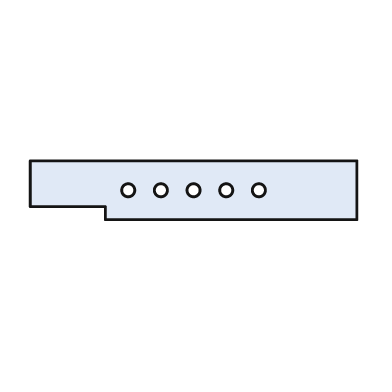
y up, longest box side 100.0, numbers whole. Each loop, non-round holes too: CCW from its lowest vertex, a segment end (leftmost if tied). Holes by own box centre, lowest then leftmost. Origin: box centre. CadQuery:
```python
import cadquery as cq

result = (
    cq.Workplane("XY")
    .moveTo(-27.0, -9.0)
    .lineTo(50.0, -9.0)
    .lineTo(50.0, 9.0)
    .lineTo(-50.0, 9.0)
    .lineTo(-50.0, -5.0)
    .lineTo(-27.0, -5.0)
    .close()
    .moveTo(-20.0, 0.0)
    .circle(2.0)
    .moveTo(-10.0, 0.0)
    .circle(2.0)
    .moveTo(0.0, 0.0)
    .circle(2.0)
    .moveTo(10.0, 0.0)
    .circle(2.0)
    .moveTo(20.0, 0.0)
    .circle(2.0)
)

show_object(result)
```